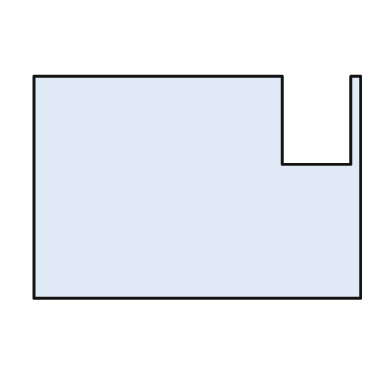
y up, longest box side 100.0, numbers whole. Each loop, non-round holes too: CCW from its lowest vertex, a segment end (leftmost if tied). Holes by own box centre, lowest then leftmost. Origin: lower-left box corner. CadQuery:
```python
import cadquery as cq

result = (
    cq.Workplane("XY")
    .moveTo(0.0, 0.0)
    .lineTo(100.0, 0.0)
    .lineTo(100.0, 68.0)
    .lineTo(97.0, 68.0)
    .lineTo(97.0, 41.0)
    .lineTo(76.0, 41.0)
    .lineTo(76.0, 68.0)
    .lineTo(0.0, 68.0)
    .close()
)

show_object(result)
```